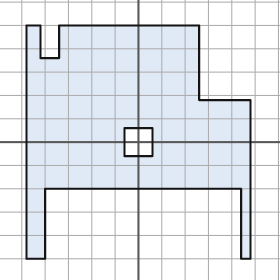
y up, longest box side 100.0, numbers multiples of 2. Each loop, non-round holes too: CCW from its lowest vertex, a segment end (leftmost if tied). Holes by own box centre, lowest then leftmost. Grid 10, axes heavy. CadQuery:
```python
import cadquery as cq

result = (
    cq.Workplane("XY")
    .moveTo(-48.0, -50.0)
    .lineTo(-40.0, -50.0)
    .lineTo(-40.0, -20.0)
    .lineTo(44.0, -20.0)
    .lineTo(44.0, -50.0)
    .lineTo(48.0, -50.0)
    .lineTo(48.0, 18.0)
    .lineTo(26.0, 18.0)
    .lineTo(26.0, 50.0)
    .lineTo(-34.0, 50.0)
    .lineTo(-34.0, 36.0)
    .lineTo(-42.0, 36.0)
    .lineTo(-42.0, 50.0)
    .lineTo(-48.0, 50.0)
    .close()
    .moveTo(-6.0, -6.0)
    .lineTo(6.0, -6.0)
    .lineTo(6.0, 6.0)
    .lineTo(-6.0, 6.0)
    .close()
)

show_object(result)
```